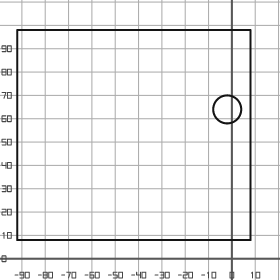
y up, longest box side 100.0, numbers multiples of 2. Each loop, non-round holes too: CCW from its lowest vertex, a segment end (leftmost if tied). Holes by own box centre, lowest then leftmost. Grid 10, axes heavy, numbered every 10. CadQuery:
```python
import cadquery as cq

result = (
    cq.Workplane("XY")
    .moveTo(-92.0, 8.0)
    .lineTo(8.0, 8.0)
    .lineTo(8.0, 98.0)
    .lineTo(-92.0, 98.0)
    .close()
    .moveTo(-2.0, 64.0)
    .circle(6.0)
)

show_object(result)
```